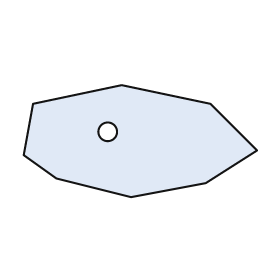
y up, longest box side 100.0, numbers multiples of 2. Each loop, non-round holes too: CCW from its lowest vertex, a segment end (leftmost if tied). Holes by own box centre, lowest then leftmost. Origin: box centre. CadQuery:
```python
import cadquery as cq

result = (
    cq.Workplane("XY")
    .moveTo(-4.0, -24.0)
    .lineTo(28.0, -18.0)
    .lineTo(50.0, -4.0)
    .lineTo(30.0, 16.0)
    .lineTo(-8.0, 24.0)
    .lineTo(-46.0, 16.0)
    .lineTo(-50.0, -6.0)
    .lineTo(-36.0, -16.0)
    .close()
    .moveTo(-14.0, 4.0)
    .circle(4.0)
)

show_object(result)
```